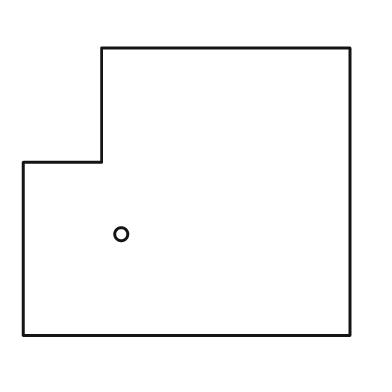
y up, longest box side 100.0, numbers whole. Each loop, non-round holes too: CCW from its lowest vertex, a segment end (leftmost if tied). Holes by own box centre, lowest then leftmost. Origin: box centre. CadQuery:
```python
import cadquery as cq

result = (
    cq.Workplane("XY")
    .moveTo(-50.0, -44.0)
    .lineTo(50.0, -44.0)
    .lineTo(50.0, 44.0)
    .lineTo(-26.0, 44.0)
    .lineTo(-26.0, 9.0)
    .lineTo(-50.0, 9.0)
    .close()
    .moveTo(-20.0, -13.0)
    .circle(2.0)
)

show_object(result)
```